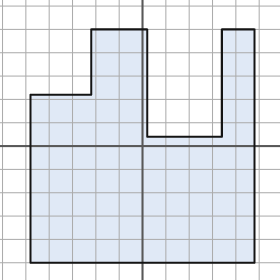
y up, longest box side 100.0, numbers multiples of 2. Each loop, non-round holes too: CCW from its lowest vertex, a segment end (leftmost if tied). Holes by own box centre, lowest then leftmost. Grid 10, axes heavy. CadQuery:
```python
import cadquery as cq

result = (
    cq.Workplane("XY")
    .moveTo(-48.0, -50.0)
    .lineTo(48.0, -50.0)
    .lineTo(48.0, 50.0)
    .lineTo(34.0, 50.0)
    .lineTo(34.0, 4.0)
    .lineTo(2.0, 4.0)
    .lineTo(2.0, 50.0)
    .lineTo(-22.0, 50.0)
    .lineTo(-22.0, 22.0)
    .lineTo(-48.0, 22.0)
    .close()
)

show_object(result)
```